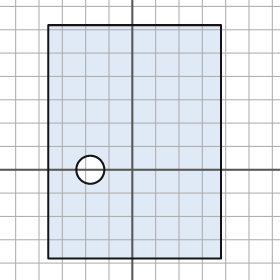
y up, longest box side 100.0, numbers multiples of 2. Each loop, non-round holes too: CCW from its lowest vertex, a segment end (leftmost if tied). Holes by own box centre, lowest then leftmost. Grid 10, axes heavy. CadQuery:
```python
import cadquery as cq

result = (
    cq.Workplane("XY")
    .moveTo(-36.0, -38.0)
    .lineTo(38.0, -38.0)
    .lineTo(38.0, 62.0)
    .lineTo(-36.0, 62.0)
    .close()
    .moveTo(-18.0, 0.0)
    .circle(6.0)
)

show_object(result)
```